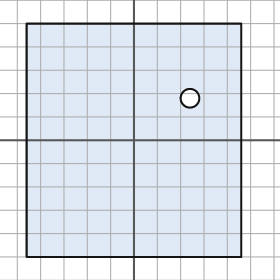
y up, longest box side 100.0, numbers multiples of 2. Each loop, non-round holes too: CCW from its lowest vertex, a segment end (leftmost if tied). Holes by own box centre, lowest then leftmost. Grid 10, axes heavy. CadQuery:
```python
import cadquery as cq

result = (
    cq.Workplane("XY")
    .moveTo(-46.0, -50.0)
    .lineTo(46.0, -50.0)
    .lineTo(46.0, 50.0)
    .lineTo(-46.0, 50.0)
    .close()
    .moveTo(24.0, 18.0)
    .circle(4.0)
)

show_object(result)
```